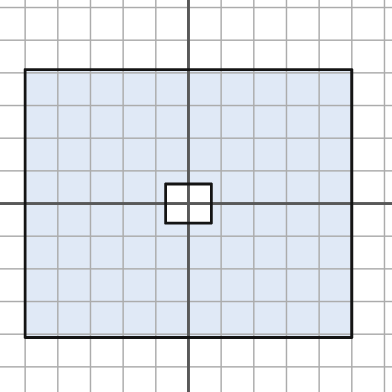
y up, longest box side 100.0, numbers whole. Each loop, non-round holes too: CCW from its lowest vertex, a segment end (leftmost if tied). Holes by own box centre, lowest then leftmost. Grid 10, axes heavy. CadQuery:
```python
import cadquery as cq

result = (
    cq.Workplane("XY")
    .moveTo(-50.0, -41.0)
    .lineTo(50.0, -41.0)
    .lineTo(50.0, 41.0)
    .lineTo(-50.0, 41.0)
    .close()
    .moveTo(-7.0, -6.0)
    .lineTo(7.0, -6.0)
    .lineTo(7.0, 6.0)
    .lineTo(-7.0, 6.0)
    .close()
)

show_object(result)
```